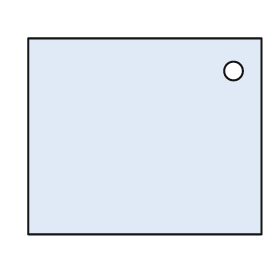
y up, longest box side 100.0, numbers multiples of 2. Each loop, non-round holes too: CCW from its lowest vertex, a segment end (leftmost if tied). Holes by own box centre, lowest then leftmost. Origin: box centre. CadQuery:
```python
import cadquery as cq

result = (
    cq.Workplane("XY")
    .moveTo(-50.0, -42.0)
    .lineTo(50.0, -42.0)
    .lineTo(50.0, 42.0)
    .lineTo(-50.0, 42.0)
    .close()
    .moveTo(38.0, 28.0)
    .circle(4.0)
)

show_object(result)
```